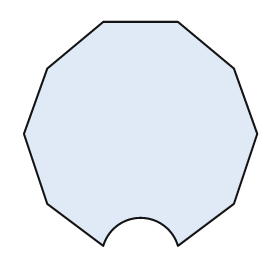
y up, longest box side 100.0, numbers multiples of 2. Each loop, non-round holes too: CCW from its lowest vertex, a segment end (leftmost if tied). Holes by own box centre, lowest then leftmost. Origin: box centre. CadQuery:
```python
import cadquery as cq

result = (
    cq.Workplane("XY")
    .moveTo(-16.0, -48.0)
    .threePointArc((0.0, -36.0), (16.0, -48.0))
    .lineTo(40.0, -30.0)
    .lineTo(50.0, 0.0)
    .lineTo(40.0, 28.0)
    .lineTo(16.0, 48.0)
    .lineTo(-16.0, 48.0)
    .lineTo(-40.0, 28.0)
    .lineTo(-50.0, 0.0)
    .lineTo(-40.0, -30.0)
    .close()
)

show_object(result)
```